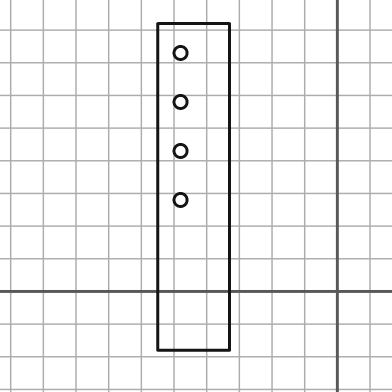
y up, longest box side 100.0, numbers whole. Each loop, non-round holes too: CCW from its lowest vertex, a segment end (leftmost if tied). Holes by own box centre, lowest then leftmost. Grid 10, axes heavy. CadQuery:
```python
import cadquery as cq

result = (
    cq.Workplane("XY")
    .moveTo(-55.0, -18.0)
    .lineTo(-33.0, -18.0)
    .lineTo(-33.0, 82.0)
    .lineTo(-55.0, 82.0)
    .close()
    .moveTo(-48.0, 28.0)
    .circle(2.0)
    .moveTo(-48.0, 43.0)
    .circle(2.0)
    .moveTo(-48.0, 58.0)
    .circle(2.0)
    .moveTo(-48.0, 73.0)
    .circle(2.0)
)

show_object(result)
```